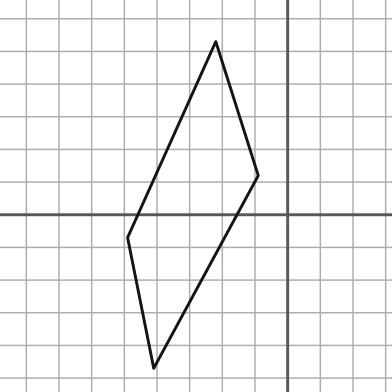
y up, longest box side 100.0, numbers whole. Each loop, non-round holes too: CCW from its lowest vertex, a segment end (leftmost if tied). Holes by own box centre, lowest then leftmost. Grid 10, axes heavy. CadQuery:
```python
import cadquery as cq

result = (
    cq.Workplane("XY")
    .moveTo(-41.0, -47.0)
    .lineTo(-9.0, 12.0)
    .lineTo(-22.0, 53.0)
    .lineTo(-49.0, -7.0)
    .close()
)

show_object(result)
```